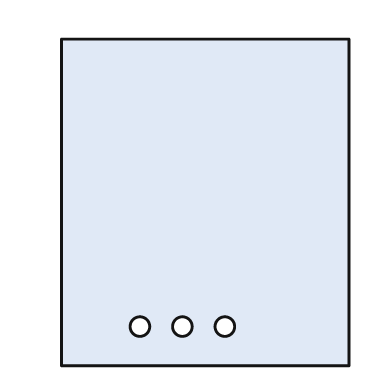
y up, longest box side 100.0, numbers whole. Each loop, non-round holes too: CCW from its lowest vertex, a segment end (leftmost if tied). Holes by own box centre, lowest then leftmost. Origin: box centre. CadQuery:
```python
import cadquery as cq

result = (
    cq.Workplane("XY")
    .moveTo(-44.0, -50.0)
    .lineTo(44.0, -50.0)
    .lineTo(44.0, 50.0)
    .lineTo(-44.0, 50.0)
    .close()
    .moveTo(-20.0, -38.0)
    .circle(3.0)
    .moveTo(-7.0, -38.0)
    .circle(3.0)
    .moveTo(6.0, -38.0)
    .circle(3.0)
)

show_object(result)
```